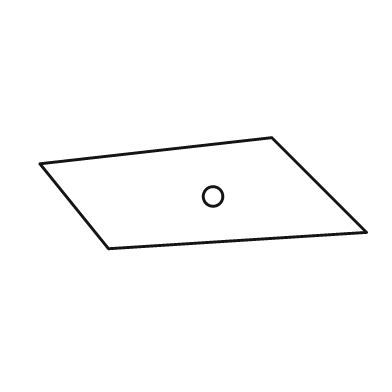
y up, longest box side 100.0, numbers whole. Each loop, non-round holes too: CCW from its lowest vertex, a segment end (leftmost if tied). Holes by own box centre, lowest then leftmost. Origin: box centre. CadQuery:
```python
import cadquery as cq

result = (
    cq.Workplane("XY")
    .moveTo(-29.0, -17.0)
    .lineTo(50.0, -12.0)
    .lineTo(21.0, 17.0)
    .lineTo(-50.0, 9.0)
    .close()
    .moveTo(3.0, -1.0)
    .circle(3.0)
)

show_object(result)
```